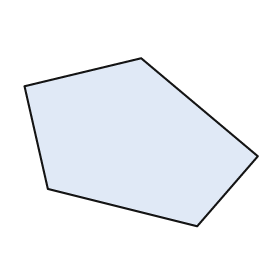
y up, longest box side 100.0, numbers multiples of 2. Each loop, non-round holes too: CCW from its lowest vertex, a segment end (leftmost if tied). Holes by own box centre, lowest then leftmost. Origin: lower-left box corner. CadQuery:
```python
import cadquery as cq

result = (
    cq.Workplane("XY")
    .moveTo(74.0, 0.0)
    .lineTo(100.0, 30.0)
    .lineTo(50.0, 72.0)
    .lineTo(0.0, 60.0)
    .lineTo(10.0, 16.0)
    .close()
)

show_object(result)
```